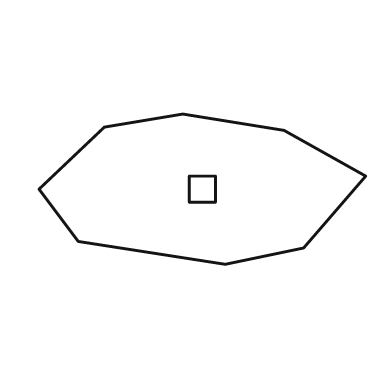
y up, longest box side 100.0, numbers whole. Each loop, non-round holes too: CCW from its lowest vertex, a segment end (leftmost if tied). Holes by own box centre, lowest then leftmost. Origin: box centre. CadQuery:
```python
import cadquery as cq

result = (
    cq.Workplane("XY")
    .moveTo(7.0, -23.0)
    .lineTo(31.0, -18.0)
    .lineTo(50.0, 4.0)
    .lineTo(25.0, 18.0)
    .lineTo(-6.0, 23.0)
    .lineTo(-30.0, 19.0)
    .lineTo(-50.0, 0.0)
    .lineTo(-38.0, -16.0)
    .close()
    .moveTo(-4.0, -4.0)
    .lineTo(4.0, -4.0)
    .lineTo(4.0, 4.0)
    .lineTo(-4.0, 4.0)
    .close()
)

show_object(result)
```